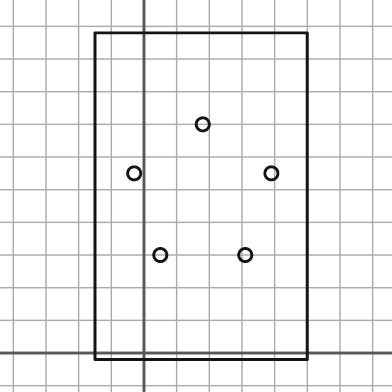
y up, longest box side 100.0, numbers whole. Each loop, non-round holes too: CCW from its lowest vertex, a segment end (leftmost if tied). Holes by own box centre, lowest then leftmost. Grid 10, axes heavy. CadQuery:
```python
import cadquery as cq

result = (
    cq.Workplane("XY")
    .moveTo(-15.0, -2.0)
    .lineTo(50.0, -2.0)
    .lineTo(50.0, 98.0)
    .lineTo(-15.0, 98.0)
    .close()
    .moveTo(5.0, 30.0)
    .circle(2.0)
    .moveTo(31.0, 30.0)
    .circle(2.0)
    .moveTo(-3.0, 55.0)
    .circle(2.0)
    .moveTo(39.0, 55.0)
    .circle(2.0)
    .moveTo(18.0, 70.0)
    .circle(2.0)
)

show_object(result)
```